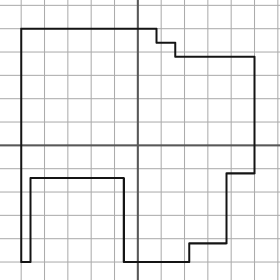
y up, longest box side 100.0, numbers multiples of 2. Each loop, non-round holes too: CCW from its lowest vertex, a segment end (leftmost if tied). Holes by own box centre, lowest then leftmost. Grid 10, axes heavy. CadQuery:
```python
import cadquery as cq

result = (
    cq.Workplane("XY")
    .moveTo(-50.0, -50.0)
    .lineTo(-46.0, -50.0)
    .lineTo(-46.0, -14.0)
    .lineTo(-6.0, -14.0)
    .lineTo(-6.0, -50.0)
    .lineTo(22.0, -50.0)
    .lineTo(22.0, -42.0)
    .lineTo(38.0, -42.0)
    .lineTo(38.0, -12.0)
    .lineTo(50.0, -12.0)
    .lineTo(50.0, 38.0)
    .lineTo(16.0, 38.0)
    .lineTo(16.0, 44.0)
    .lineTo(8.0, 44.0)
    .lineTo(8.0, 50.0)
    .lineTo(-50.0, 50.0)
    .close()
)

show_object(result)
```